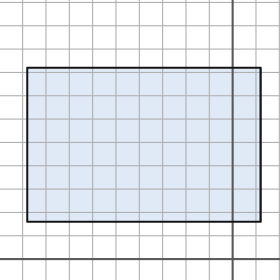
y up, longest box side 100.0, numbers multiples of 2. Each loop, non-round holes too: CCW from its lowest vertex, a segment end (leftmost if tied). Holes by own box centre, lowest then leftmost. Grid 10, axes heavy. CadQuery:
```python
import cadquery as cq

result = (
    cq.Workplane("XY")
    .moveTo(-88.0, 16.0)
    .lineTo(12.0, 16.0)
    .lineTo(12.0, 82.0)
    .lineTo(-88.0, 82.0)
    .close()
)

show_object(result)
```